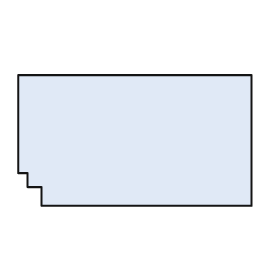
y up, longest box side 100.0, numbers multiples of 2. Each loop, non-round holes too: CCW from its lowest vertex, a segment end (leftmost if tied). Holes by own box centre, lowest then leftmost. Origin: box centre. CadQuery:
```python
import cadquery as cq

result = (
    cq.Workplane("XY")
    .moveTo(-40.0, -28.0)
    .lineTo(50.0, -28.0)
    .lineTo(50.0, 28.0)
    .lineTo(-50.0, 28.0)
    .lineTo(-50.0, -14.0)
    .lineTo(-46.0, -14.0)
    .lineTo(-46.0, -20.0)
    .lineTo(-40.0, -20.0)
    .close()
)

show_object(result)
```